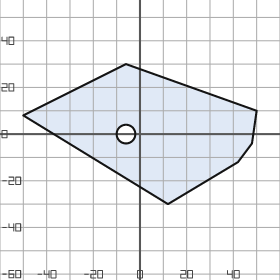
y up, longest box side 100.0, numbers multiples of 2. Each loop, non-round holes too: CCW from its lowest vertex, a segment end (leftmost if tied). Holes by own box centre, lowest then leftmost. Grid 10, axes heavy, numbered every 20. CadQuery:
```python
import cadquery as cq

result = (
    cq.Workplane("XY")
    .moveTo(12.0, -30.0)
    .lineTo(42.0, -12.0)
    .lineTo(48.0, -4.0)
    .lineTo(50.0, 10.0)
    .lineTo(-6.0, 30.0)
    .lineTo(-50.0, 8.0)
    .close()
    .moveTo(-6.0, 0.0)
    .circle(4.0)
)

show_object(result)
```